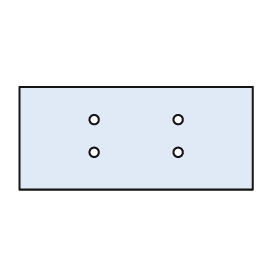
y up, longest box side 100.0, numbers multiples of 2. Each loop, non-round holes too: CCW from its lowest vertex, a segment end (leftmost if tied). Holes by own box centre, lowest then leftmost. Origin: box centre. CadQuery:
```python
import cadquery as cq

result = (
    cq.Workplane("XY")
    .moveTo(-50.0, -22.0)
    .lineTo(50.0, -22.0)
    .lineTo(50.0, 22.0)
    .lineTo(-50.0, 22.0)
    .close()
    .moveTo(-18.0, -6.0)
    .circle(2.0)
    .moveTo(18.0, -6.0)
    .circle(2.0)
    .moveTo(-18.0, 8.0)
    .circle(2.0)
    .moveTo(18.0, 8.0)
    .circle(2.0)
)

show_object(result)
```